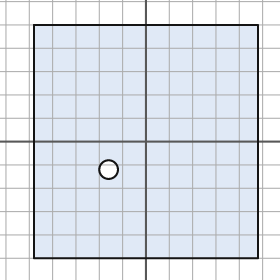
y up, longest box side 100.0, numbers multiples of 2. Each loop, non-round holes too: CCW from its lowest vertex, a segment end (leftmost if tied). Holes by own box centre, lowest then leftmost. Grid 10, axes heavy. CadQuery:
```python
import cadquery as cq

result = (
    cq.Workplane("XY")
    .moveTo(-48.0, -50.0)
    .lineTo(48.0, -50.0)
    .lineTo(48.0, 50.0)
    .lineTo(-48.0, 50.0)
    .close()
    .moveTo(-16.0, -12.0)
    .circle(4.0)
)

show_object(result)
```